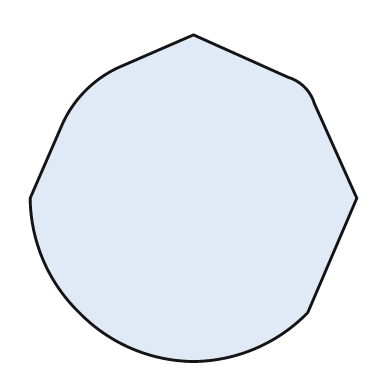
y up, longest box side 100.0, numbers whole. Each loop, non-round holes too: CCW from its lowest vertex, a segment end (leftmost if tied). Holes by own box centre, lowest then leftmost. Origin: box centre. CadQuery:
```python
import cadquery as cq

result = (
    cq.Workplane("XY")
    .moveTo(0.0, -50.0)
    .threePointArc((19.0, -46.0), (35.0, -35.0))
    .lineTo(50.0, 0.0)
    .lineTo(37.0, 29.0)
    .threePointArc((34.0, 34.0), (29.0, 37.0))
    .lineTo(0.0, 50.0)
    .lineTo(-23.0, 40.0)
    .threePointArc((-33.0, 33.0), (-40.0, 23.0))
    .lineTo(-50.0, 0.0)
    .threePointArc((-46.0, -19.0), (-35.0, -35.0))
    .threePointArc((-19.0, -46.0), (0.0, -50.0))
    .close()
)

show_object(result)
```